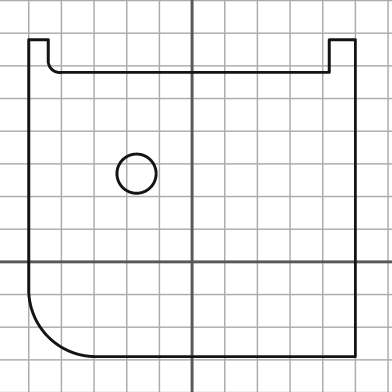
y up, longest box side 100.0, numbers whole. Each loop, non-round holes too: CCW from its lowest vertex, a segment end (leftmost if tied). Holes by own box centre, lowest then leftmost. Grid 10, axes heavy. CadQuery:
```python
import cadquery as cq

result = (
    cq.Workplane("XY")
    .moveTo(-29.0, -29.0)
    .lineTo(50.0, -29.0)
    .lineTo(50.0, 68.0)
    .lineTo(42.0, 68.0)
    .lineTo(42.0, 58.0)
    .lineTo(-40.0, 58.0)
    .threePointArc((-43.0, 59.0), (-44.0, 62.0))
    .lineTo(-44.0, 68.0)
    .lineTo(-50.0, 68.0)
    .lineTo(-50.0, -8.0)
    .threePointArc((-44.0, -23.0), (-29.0, -29.0))
    .close()
    .moveTo(-17.0, 27.0)
    .circle(6.0)
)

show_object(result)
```